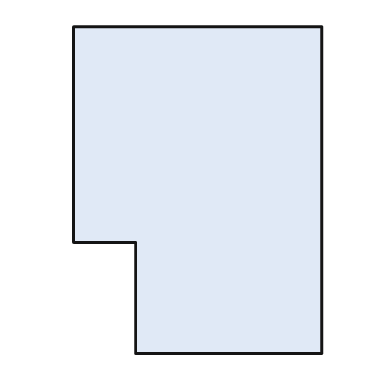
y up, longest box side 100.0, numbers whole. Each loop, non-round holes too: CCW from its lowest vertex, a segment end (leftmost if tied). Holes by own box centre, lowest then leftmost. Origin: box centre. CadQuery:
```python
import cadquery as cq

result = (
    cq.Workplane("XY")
    .moveTo(-19.0, -50.0)
    .lineTo(38.0, -50.0)
    .lineTo(38.0, 50.0)
    .lineTo(-38.0, 50.0)
    .lineTo(-38.0, -16.0)
    .lineTo(-19.0, -16.0)
    .close()
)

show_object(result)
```